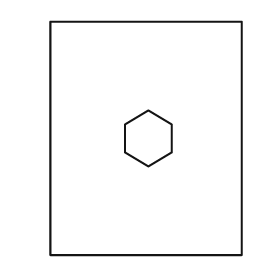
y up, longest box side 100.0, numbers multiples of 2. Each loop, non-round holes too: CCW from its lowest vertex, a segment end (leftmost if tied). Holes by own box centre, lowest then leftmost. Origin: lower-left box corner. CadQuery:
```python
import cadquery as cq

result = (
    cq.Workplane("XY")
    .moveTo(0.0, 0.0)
    .lineTo(82.0, 0.0)
    .lineTo(82.0, 100.0)
    .lineTo(0.0, 100.0)
    .close()
    .moveTo(42.0, 38.0)
    .lineTo(52.0, 44.0)
    .lineTo(52.0, 56.0)
    .lineTo(42.0, 62.0)
    .lineTo(32.0, 56.0)
    .lineTo(32.0, 44.0)
    .close()
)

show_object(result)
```